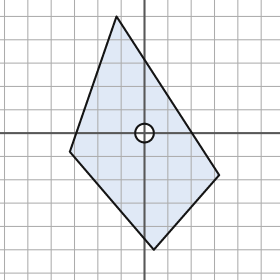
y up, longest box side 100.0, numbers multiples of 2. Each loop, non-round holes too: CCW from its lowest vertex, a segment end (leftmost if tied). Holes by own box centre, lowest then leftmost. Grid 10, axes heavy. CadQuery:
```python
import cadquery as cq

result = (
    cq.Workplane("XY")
    .moveTo(4.0, -50.0)
    .lineTo(32.0, -18.0)
    .lineTo(-12.0, 50.0)
    .lineTo(-32.0, -8.0)
    .close()
    .moveTo(0.0, 0.0)
    .circle(4.0)
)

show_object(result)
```